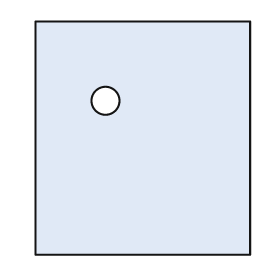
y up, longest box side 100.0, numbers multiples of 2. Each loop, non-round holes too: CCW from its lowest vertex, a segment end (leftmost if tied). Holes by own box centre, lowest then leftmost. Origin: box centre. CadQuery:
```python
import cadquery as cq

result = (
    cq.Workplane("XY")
    .moveTo(-46.0, -50.0)
    .lineTo(46.0, -50.0)
    .lineTo(46.0, 50.0)
    .lineTo(-46.0, 50.0)
    .close()
    .moveTo(-16.0, 16.0)
    .circle(6.0)
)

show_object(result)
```